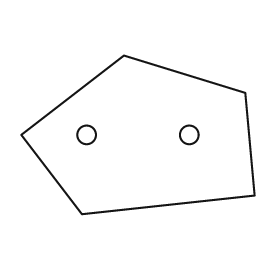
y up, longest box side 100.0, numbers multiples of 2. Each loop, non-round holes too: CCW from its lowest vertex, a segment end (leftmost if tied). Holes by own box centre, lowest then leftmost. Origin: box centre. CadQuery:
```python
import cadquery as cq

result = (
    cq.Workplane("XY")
    .moveTo(-24.0, -34.0)
    .lineTo(50.0, -26.0)
    .lineTo(46.0, 18.0)
    .lineTo(-6.0, 34.0)
    .lineTo(-50.0, 0.0)
    .close()
    .moveTo(-22.0, 0.0)
    .circle(4.0)
    .moveTo(22.0, 0.0)
    .circle(4.0)
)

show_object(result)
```